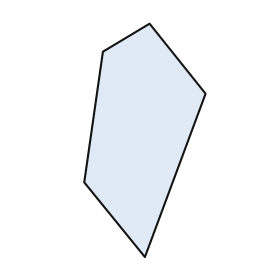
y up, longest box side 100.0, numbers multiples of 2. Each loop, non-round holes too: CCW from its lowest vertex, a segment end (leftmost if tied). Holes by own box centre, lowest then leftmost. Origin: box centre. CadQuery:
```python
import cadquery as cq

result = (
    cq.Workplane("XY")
    .moveTo(0.0, -50.0)
    .lineTo(26.0, 20.0)
    .lineTo(2.0, 50.0)
    .lineTo(-18.0, 38.0)
    .lineTo(-26.0, -18.0)
    .close()
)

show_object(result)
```